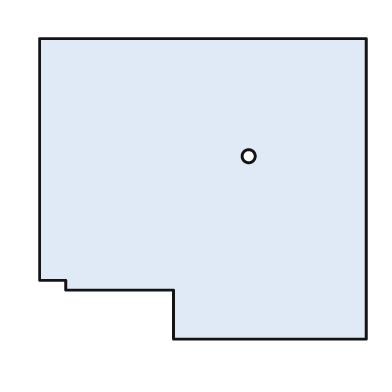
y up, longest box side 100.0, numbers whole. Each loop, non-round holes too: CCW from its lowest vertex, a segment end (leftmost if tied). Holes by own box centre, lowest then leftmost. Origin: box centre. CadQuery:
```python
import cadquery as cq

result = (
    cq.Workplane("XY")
    .moveTo(-9.0, -46.0)
    .lineTo(50.0, -46.0)
    .lineTo(50.0, 46.0)
    .lineTo(-50.0, 46.0)
    .lineTo(-50.0, -28.0)
    .lineTo(-42.0, -28.0)
    .lineTo(-42.0, -31.0)
    .lineTo(-9.0, -31.0)
    .close()
    .moveTo(14.0, 10.0)
    .circle(2.0)
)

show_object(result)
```